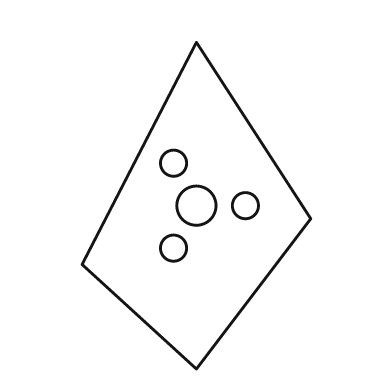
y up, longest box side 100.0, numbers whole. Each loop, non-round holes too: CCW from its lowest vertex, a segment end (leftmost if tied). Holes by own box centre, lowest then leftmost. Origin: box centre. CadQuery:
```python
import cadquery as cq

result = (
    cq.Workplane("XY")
    .moveTo(0.0, -50.0)
    .lineTo(35.0, -4.0)
    .lineTo(0.0, 50.0)
    .lineTo(-35.0, -18.0)
    .close()
    .moveTo(-7.0, -13.0)
    .circle(4.0)
    .moveTo(0.0, 0.0)
    .circle(6.0)
    .moveTo(15.0, 0.0)
    .circle(4.0)
    .moveTo(-7.0, 13.0)
    .circle(4.0)
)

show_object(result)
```